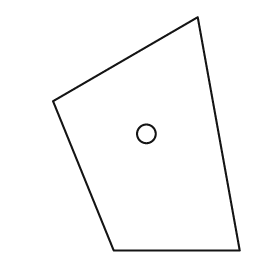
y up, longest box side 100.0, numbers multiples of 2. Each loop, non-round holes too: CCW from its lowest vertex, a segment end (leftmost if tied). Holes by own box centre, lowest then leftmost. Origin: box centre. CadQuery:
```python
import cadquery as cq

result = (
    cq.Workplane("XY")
    .moveTo(-14.0, -50.0)
    .lineTo(40.0, -50.0)
    .lineTo(22.0, 50.0)
    .lineTo(-40.0, 14.0)
    .close()
    .moveTo(0.0, 0.0)
    .circle(4.0)
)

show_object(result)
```